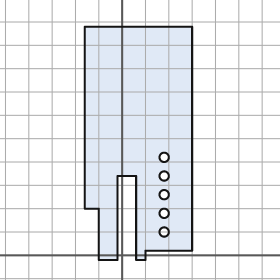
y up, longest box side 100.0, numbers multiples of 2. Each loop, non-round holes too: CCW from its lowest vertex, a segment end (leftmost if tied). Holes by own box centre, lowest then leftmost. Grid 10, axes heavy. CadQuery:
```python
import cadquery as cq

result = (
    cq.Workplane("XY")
    .moveTo(-10.0, -2.0)
    .lineTo(-2.0, -2.0)
    .lineTo(-2.0, 34.0)
    .lineTo(6.0, 34.0)
    .lineTo(6.0, -2.0)
    .lineTo(10.0, -2.0)
    .lineTo(10.0, 2.0)
    .lineTo(30.0, 2.0)
    .lineTo(30.0, 98.0)
    .lineTo(-16.0, 98.0)
    .lineTo(-16.0, 20.0)
    .lineTo(-10.0, 20.0)
    .close()
    .moveTo(18.0, 10.0)
    .circle(2.0)
    .moveTo(18.0, 18.0)
    .circle(2.0)
    .moveTo(18.0, 26.0)
    .circle(2.0)
    .moveTo(18.0, 34.0)
    .circle(2.0)
    .moveTo(18.0, 42.0)
    .circle(2.0)
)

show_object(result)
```